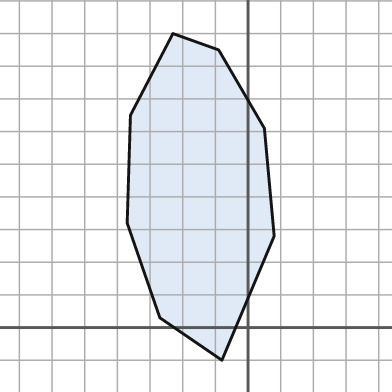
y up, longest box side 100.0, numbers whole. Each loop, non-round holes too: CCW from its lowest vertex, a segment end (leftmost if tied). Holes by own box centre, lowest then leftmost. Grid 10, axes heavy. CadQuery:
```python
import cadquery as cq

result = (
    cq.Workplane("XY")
    .moveTo(-8.0, -10.0)
    .lineTo(8.0, 28.0)
    .lineTo(5.0, 61.0)
    .lineTo(-9.0, 85.0)
    .lineTo(-23.0, 90.0)
    .lineTo(-36.0, 65.0)
    .lineTo(-37.0, 32.0)
    .lineTo(-27.0, 3.0)
    .close()
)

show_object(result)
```